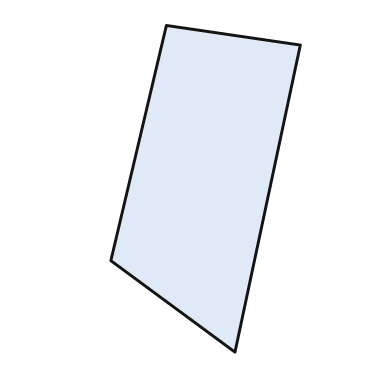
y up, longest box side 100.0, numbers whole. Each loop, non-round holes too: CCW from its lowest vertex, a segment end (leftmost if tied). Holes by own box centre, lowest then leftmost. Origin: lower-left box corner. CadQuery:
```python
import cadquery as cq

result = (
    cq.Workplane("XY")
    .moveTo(38.0, 0.0)
    .lineTo(58.0, 94.0)
    .lineTo(17.0, 100.0)
    .lineTo(0.0, 28.0)
    .close()
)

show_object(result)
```